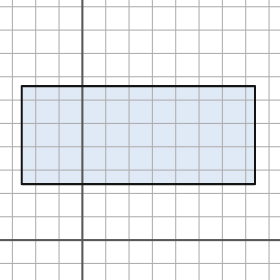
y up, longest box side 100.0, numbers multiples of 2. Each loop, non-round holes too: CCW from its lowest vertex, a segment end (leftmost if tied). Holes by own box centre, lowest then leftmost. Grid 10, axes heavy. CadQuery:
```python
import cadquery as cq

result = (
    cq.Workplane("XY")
    .moveTo(-26.0, 24.0)
    .lineTo(74.0, 24.0)
    .lineTo(74.0, 66.0)
    .lineTo(-26.0, 66.0)
    .close()
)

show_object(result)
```